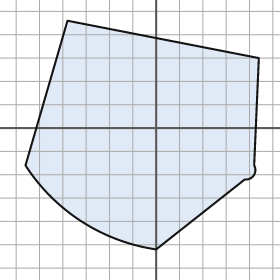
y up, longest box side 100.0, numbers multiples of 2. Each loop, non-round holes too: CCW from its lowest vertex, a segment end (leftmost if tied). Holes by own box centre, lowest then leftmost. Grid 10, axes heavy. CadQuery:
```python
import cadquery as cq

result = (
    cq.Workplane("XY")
    .moveTo(0.0, -52.0)
    .lineTo(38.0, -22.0)
    .threePointArc((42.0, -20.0), (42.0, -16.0))
    .lineTo(44.0, 30.0)
    .lineTo(-38.0, 46.0)
    .lineTo(-56.0, -16.0)
    .threePointArc((-32.0, -40.0), (0.0, -52.0))
    .close()
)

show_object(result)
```